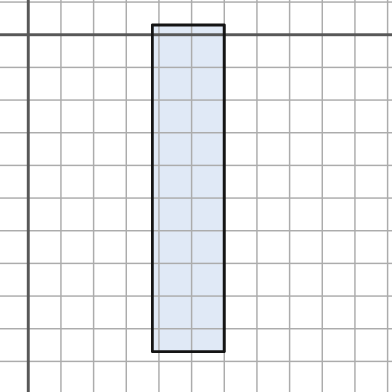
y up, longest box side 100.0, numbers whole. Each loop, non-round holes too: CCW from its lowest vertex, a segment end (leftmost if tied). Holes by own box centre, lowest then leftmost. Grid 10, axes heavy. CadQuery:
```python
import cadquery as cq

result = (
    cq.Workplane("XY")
    .moveTo(38.0, -97.0)
    .lineTo(60.0, -97.0)
    .lineTo(60.0, 3.0)
    .lineTo(38.0, 3.0)
    .close()
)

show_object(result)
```